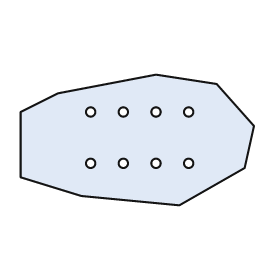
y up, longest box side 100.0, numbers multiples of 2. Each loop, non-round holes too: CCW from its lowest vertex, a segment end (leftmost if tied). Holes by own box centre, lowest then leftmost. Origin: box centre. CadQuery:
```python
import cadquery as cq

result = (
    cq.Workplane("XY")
    .moveTo(18.0, -28.0)
    .lineTo(46.0, -12.0)
    .lineTo(50.0, 6.0)
    .lineTo(34.0, 24.0)
    .lineTo(8.0, 28.0)
    .lineTo(-34.0, 20.0)
    .lineTo(-50.0, 12.0)
    .lineTo(-50.0, -16.0)
    .lineTo(-24.0, -24.0)
    .close()
    .moveTo(-20.0, -10.0)
    .circle(2.0)
    .moveTo(-6.0, -10.0)
    .circle(2.0)
    .moveTo(8.0, -10.0)
    .circle(2.0)
    .moveTo(22.0, -10.0)
    .circle(2.0)
    .moveTo(-20.0, 12.0)
    .circle(2.0)
    .moveTo(-6.0, 12.0)
    .circle(2.0)
    .moveTo(8.0, 12.0)
    .circle(2.0)
    .moveTo(22.0, 12.0)
    .circle(2.0)
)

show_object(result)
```